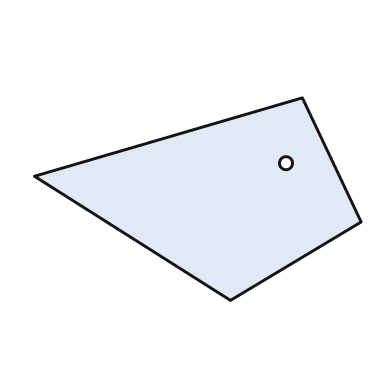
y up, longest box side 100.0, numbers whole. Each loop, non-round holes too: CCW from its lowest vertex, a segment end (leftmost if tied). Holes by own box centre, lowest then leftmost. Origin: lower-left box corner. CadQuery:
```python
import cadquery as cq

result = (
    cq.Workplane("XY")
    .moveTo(60.0, 0.0)
    .lineTo(100.0, 24.0)
    .lineTo(82.0, 62.0)
    .lineTo(0.0, 38.0)
    .close()
    .moveTo(77.0, 42.0)
    .circle(2.0)
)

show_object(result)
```